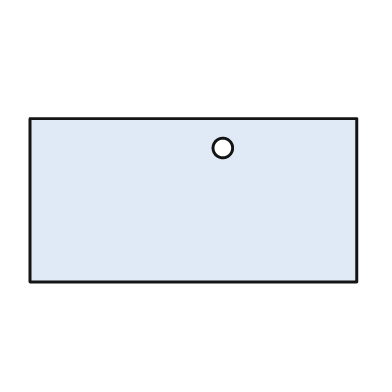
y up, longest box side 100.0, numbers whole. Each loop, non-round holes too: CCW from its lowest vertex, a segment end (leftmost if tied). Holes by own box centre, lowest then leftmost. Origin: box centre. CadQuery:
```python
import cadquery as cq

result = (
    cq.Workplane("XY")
    .moveTo(-50.0, -25.0)
    .lineTo(50.0, -25.0)
    .lineTo(50.0, 25.0)
    .lineTo(-50.0, 25.0)
    .close()
    .moveTo(9.0, 16.0)
    .circle(3.0)
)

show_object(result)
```